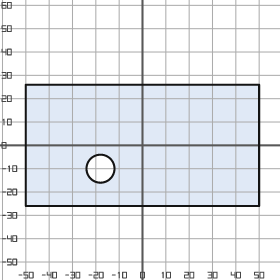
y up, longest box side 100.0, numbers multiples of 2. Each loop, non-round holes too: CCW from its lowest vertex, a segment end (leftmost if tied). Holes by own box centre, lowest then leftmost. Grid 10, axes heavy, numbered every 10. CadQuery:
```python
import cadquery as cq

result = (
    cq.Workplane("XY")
    .moveTo(-50.0, -26.0)
    .lineTo(50.0, -26.0)
    .lineTo(50.0, 26.0)
    .lineTo(-50.0, 26.0)
    .close()
    .moveTo(-18.0, -10.0)
    .circle(6.0)
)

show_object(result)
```